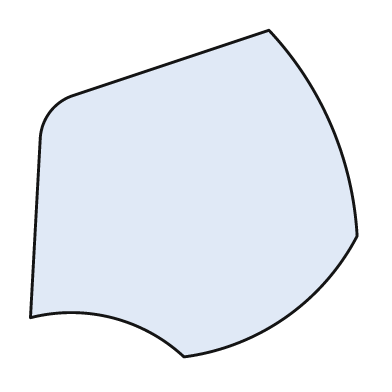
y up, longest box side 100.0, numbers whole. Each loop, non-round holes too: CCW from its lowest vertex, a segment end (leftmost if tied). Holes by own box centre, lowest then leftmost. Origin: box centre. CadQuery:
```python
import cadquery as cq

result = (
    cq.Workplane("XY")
    .moveTo(-3.0, -50.0)
    .threePointArc((28.0, -38.0), (50.0, -13.0))
    .threePointArc((42.0, 21.0), (23.0, 50.0))
    .lineTo(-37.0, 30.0)
    .threePointArc((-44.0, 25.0), (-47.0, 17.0))
    .lineTo(-50.0, -38.0)
    .threePointArc((-25.0, -38.0), (-3.0, -50.0))
    .close()
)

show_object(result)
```